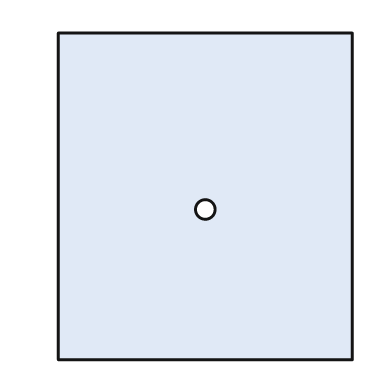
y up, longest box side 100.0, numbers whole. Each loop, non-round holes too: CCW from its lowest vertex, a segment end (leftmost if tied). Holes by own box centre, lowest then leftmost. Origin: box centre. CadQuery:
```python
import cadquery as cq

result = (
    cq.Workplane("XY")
    .moveTo(-45.0, -50.0)
    .lineTo(45.0, -50.0)
    .lineTo(45.0, 50.0)
    .lineTo(-45.0, 50.0)
    .close()
    .moveTo(0.0, -4.0)
    .circle(3.0)
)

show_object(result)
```